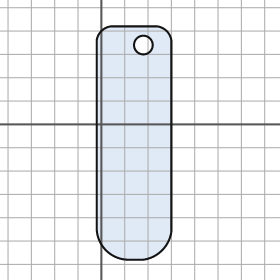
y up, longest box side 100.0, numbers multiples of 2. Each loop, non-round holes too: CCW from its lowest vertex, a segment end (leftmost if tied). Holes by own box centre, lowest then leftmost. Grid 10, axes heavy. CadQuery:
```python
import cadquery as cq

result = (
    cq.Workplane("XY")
    .moveTo(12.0, -58.0)
    .lineTo(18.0, -58.0)
    .threePointArc((26.0, -54.0), (30.0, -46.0))
    .lineTo(30.0, 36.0)
    .threePointArc((28.0, 40.0), (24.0, 42.0))
    .lineTo(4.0, 42.0)
    .threePointArc((0.0, 40.0), (-2.0, 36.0))
    .lineTo(-2.0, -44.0)
    .threePointArc((2.0, -54.0), (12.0, -58.0))
    .close()
    .moveTo(18.0, 34.0)
    .circle(4.0)
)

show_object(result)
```